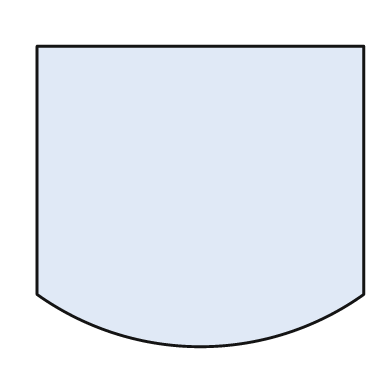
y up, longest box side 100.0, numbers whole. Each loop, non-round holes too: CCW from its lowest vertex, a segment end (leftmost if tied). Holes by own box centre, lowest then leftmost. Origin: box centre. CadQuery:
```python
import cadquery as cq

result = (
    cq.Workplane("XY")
    .moveTo(-50.0, -30.0)
    .threePointArc((0.0, -46.0), (50.0, -30.0))
    .lineTo(50.0, 46.0)
    .lineTo(-50.0, 46.0)
    .close()
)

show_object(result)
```